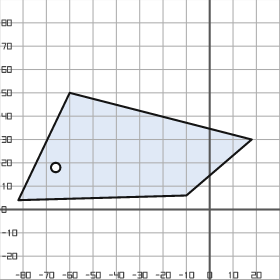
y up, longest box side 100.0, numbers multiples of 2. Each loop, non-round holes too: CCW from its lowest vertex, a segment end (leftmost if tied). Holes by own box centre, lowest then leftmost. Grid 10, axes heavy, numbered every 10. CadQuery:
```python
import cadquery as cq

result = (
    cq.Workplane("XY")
    .moveTo(-82.0, 4.0)
    .lineTo(-10.0, 6.0)
    .lineTo(18.0, 30.0)
    .lineTo(-60.0, 50.0)
    .close()
    .moveTo(-66.0, 18.0)
    .circle(2.0)
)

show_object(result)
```